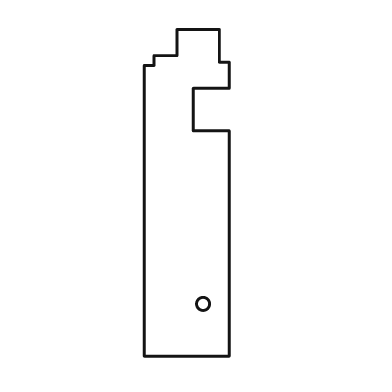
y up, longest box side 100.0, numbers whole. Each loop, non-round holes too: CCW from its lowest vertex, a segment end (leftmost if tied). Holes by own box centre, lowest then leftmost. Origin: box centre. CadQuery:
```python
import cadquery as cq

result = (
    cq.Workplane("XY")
    .moveTo(-13.0, -50.0)
    .lineTo(13.0, -50.0)
    .lineTo(13.0, 19.0)
    .lineTo(2.0, 19.0)
    .lineTo(2.0, 32.0)
    .lineTo(13.0, 32.0)
    .lineTo(13.0, 40.0)
    .lineTo(10.0, 40.0)
    .lineTo(10.0, 50.0)
    .lineTo(-3.0, 50.0)
    .lineTo(-3.0, 42.0)
    .lineTo(-10.0, 42.0)
    .lineTo(-10.0, 39.0)
    .lineTo(-13.0, 39.0)
    .close()
    .moveTo(5.0, -34.0)
    .circle(2.0)
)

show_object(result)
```